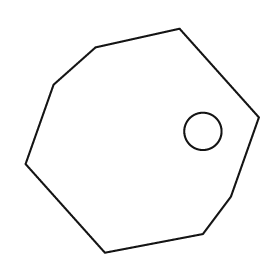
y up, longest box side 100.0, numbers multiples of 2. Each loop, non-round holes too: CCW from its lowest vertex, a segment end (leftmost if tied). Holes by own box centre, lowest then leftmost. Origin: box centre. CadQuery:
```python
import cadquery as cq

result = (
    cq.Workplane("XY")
    .moveTo(-16.0, -48.0)
    .lineTo(26.0, -40.0)
    .lineTo(38.0, -24.0)
    .lineTo(50.0, 10.0)
    .lineTo(16.0, 48.0)
    .lineTo(-20.0, 40.0)
    .lineTo(-38.0, 24.0)
    .lineTo(-50.0, -10.0)
    .close()
    .moveTo(26.0, 4.0)
    .circle(8.0)
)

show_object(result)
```